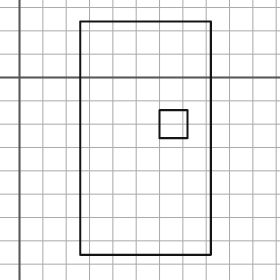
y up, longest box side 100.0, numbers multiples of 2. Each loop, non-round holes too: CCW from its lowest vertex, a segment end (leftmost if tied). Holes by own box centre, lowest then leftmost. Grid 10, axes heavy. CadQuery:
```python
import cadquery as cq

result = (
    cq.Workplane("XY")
    .moveTo(26.0, -76.0)
    .lineTo(82.0, -76.0)
    .lineTo(82.0, 24.0)
    .lineTo(26.0, 24.0)
    .close()
    .moveTo(60.0, -26.0)
    .lineTo(72.0, -26.0)
    .lineTo(72.0, -14.0)
    .lineTo(60.0, -14.0)
    .close()
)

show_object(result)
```